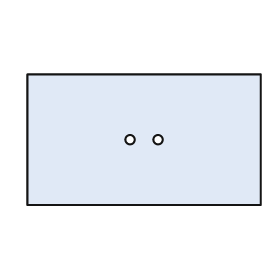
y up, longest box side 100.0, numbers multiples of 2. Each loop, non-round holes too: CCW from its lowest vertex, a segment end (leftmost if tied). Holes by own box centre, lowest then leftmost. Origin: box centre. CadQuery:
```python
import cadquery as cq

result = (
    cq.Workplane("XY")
    .moveTo(-50.0, -28.0)
    .lineTo(50.0, -28.0)
    .lineTo(50.0, 28.0)
    .lineTo(-50.0, 28.0)
    .close()
    .moveTo(-6.0, 0.0)
    .circle(2.0)
    .moveTo(6.0, 0.0)
    .circle(2.0)
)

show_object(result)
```